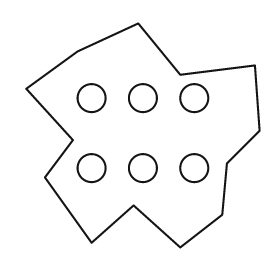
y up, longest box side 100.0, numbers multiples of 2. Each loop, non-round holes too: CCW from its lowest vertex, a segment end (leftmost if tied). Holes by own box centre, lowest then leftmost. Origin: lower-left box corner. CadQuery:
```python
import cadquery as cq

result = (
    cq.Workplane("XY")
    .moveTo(66.0, 0.0)
    .lineTo(84.0, 14.0)
    .lineTo(86.0, 36.0)
    .lineTo(100.0, 50.0)
    .lineTo(98.0, 78.0)
    .lineTo(66.0, 74.0)
    .lineTo(48.0, 96.0)
    .lineTo(22.0, 84.0)
    .lineTo(0.0, 68.0)
    .lineTo(20.0, 46.0)
    .lineTo(8.0, 30.0)
    .lineTo(28.0, 2.0)
    .lineTo(46.0, 18.0)
    .close()
    .moveTo(28.0, 34.0)
    .circle(6.0)
    .moveTo(50.0, 34.0)
    .circle(6.0)
    .moveTo(72.0, 34.0)
    .circle(6.0)
    .moveTo(28.0, 64.0)
    .circle(6.0)
    .moveTo(50.0, 64.0)
    .circle(6.0)
    .moveTo(72.0, 64.0)
    .circle(6.0)
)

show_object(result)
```